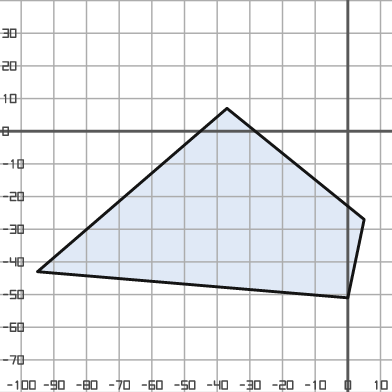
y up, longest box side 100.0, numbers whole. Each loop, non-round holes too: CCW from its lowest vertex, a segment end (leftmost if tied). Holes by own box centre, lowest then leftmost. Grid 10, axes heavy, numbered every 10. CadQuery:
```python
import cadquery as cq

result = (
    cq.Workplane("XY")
    .moveTo(0.0, -51.0)
    .lineTo(5.0, -27.0)
    .lineTo(-37.0, 7.0)
    .lineTo(-95.0, -43.0)
    .close()
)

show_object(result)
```